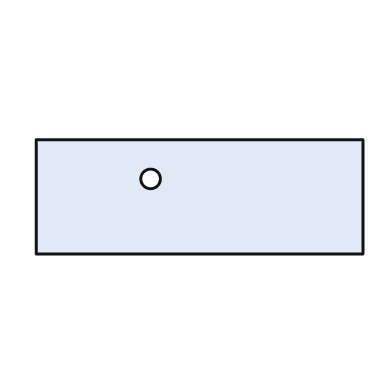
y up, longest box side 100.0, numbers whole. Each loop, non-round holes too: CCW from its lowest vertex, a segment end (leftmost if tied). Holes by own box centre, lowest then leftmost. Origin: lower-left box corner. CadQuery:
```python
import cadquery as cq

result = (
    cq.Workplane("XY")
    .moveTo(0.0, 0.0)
    .lineTo(100.0, 0.0)
    .lineTo(100.0, 35.0)
    .lineTo(0.0, 35.0)
    .close()
    .moveTo(35.0, 23.0)
    .circle(3.0)
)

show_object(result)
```